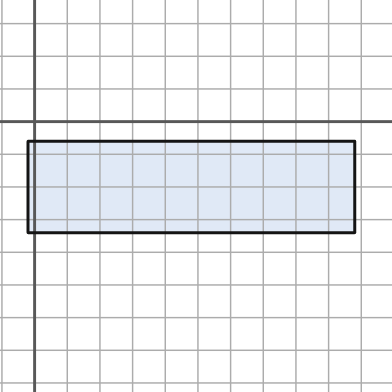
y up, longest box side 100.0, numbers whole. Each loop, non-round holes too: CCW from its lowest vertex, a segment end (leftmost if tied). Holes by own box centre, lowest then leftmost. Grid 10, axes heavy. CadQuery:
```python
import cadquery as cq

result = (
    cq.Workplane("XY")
    .moveTo(-2.0, -34.0)
    .lineTo(98.0, -34.0)
    .lineTo(98.0, -6.0)
    .lineTo(-2.0, -6.0)
    .close()
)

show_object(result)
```